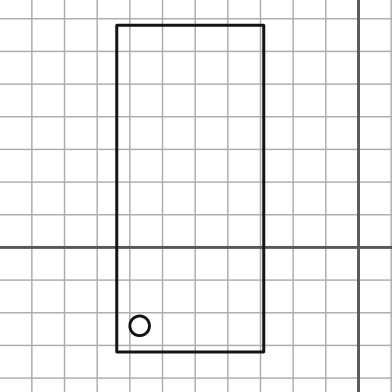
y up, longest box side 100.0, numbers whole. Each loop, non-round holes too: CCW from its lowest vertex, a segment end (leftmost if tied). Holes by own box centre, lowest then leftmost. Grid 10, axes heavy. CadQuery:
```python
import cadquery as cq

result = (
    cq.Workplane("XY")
    .moveTo(-74.0, -32.0)
    .lineTo(-29.0, -32.0)
    .lineTo(-29.0, 68.0)
    .lineTo(-74.0, 68.0)
    .close()
    .moveTo(-67.0, -24.0)
    .circle(3.0)
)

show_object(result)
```